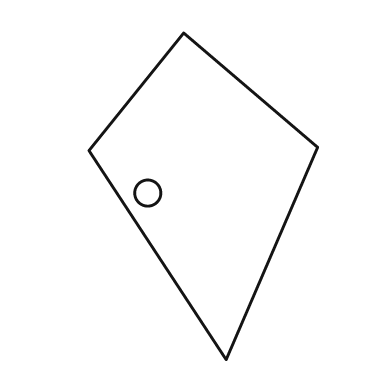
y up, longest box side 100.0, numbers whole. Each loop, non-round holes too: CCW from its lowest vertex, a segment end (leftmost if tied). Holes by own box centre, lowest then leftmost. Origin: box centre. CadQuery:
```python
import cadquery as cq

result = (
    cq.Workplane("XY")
    .moveTo(7.0, -50.0)
    .lineTo(35.0, 15.0)
    .lineTo(-6.0, 50.0)
    .lineTo(-35.0, 14.0)
    .close()
    .moveTo(-17.0, 1.0)
    .circle(4.0)
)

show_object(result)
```